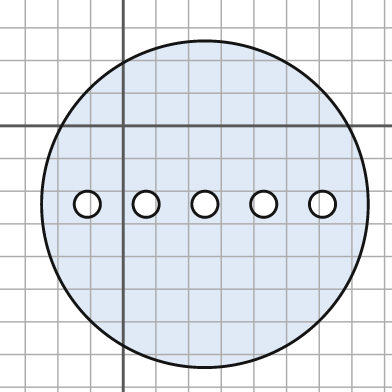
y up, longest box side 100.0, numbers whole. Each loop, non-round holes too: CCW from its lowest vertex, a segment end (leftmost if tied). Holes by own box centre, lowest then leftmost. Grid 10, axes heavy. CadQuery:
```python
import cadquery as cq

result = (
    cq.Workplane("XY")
    .moveTo(25.0, -24.0)
    .circle(50.0)
    .moveTo(-11.0, -24.0)
    .circle(4.0)
    .moveTo(7.0, -24.0)
    .circle(4.0)
    .moveTo(25.0, -24.0)
    .circle(4.0)
    .moveTo(43.0, -24.0)
    .circle(4.0)
    .moveTo(61.0, -24.0)
    .circle(4.0)
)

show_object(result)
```